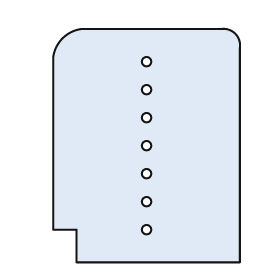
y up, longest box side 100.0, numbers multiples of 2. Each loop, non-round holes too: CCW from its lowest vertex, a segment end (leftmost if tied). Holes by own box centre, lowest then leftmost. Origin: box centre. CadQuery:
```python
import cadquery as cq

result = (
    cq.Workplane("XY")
    .moveTo(-30.0, -50.0)
    .lineTo(40.0, -50.0)
    .lineTo(40.0, 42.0)
    .threePointArc((38.0, 48.0), (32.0, 50.0))
    .lineTo(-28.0, 50.0)
    .threePointArc((-36.0, 46.0), (-40.0, 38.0))
    .lineTo(-40.0, -36.0)
    .lineTo(-30.0, -36.0)
    .close()
    .moveTo(0.0, -36.0)
    .circle(2.0)
    .moveTo(0.0, -24.0)
    .circle(2.0)
    .moveTo(0.0, -12.0)
    .circle(2.0)
    .moveTo(0.0, 0.0)
    .circle(2.0)
    .moveTo(0.0, 12.0)
    .circle(2.0)
    .moveTo(0.0, 24.0)
    .circle(2.0)
    .moveTo(0.0, 36.0)
    .circle(2.0)
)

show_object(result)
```